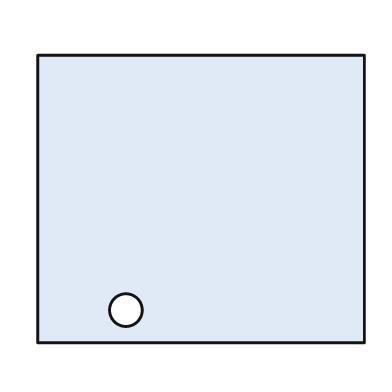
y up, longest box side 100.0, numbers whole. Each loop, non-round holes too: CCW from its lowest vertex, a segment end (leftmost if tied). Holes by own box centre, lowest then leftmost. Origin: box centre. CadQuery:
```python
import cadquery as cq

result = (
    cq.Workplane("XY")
    .moveTo(-50.0, -44.0)
    .lineTo(50.0, -44.0)
    .lineTo(50.0, 44.0)
    .lineTo(-50.0, 44.0)
    .close()
    .moveTo(-23.0, -34.0)
    .circle(5.0)
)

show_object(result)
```